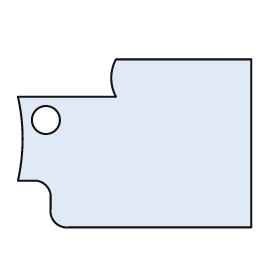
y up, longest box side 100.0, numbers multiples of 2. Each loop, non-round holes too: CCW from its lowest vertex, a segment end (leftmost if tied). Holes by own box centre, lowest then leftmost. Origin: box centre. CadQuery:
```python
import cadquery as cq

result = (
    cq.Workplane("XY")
    .moveTo(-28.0, -36.0)
    .lineTo(50.0, -36.0)
    .lineTo(50.0, 36.0)
    .lineTo(-8.0, 36.0)
    .threePointArc((-10.0, 28.0), (-8.0, 20.0))
    .lineTo(-50.0, 20.0)
    .threePointArc((-48.0, 2.0), (-50.0, -16.0))
    .lineTo(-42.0, -16.0)
    .threePointArc((-38.0, -18.0), (-36.0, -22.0))
    .lineTo(-36.0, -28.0)
    .threePointArc((-34.0, -34.0), (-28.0, -36.0))
    .close()
    .moveTo(-38.0, 10.0)
    .circle(6.0)
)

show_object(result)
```